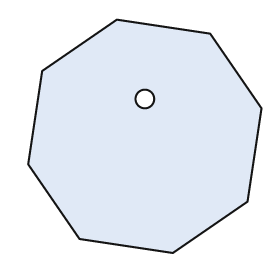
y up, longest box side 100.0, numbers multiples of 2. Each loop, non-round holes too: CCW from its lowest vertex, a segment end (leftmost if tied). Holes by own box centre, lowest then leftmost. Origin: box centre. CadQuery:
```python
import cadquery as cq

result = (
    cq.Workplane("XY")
    .moveTo(12.0, -50.0)
    .lineTo(44.0, -28.0)
    .lineTo(50.0, 12.0)
    .lineTo(28.0, 44.0)
    .lineTo(-12.0, 50.0)
    .lineTo(-44.0, 28.0)
    .lineTo(-50.0, -12.0)
    .lineTo(-28.0, -44.0)
    .close()
    .moveTo(0.0, 16.0)
    .circle(4.0)
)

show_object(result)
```